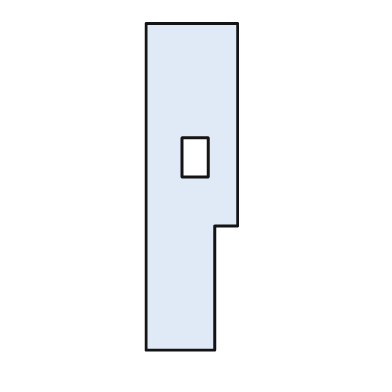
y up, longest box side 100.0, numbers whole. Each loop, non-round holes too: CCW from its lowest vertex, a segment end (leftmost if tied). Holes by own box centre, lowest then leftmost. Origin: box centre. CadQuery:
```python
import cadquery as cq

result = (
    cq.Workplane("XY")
    .moveTo(-14.0, -50.0)
    .lineTo(7.0, -50.0)
    .lineTo(7.0, -12.0)
    .lineTo(14.0, -12.0)
    .lineTo(14.0, 50.0)
    .lineTo(-14.0, 50.0)
    .close()
    .moveTo(-3.0, 3.0)
    .lineTo(5.0, 3.0)
    .lineTo(5.0, 15.0)
    .lineTo(-3.0, 15.0)
    .close()
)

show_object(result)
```